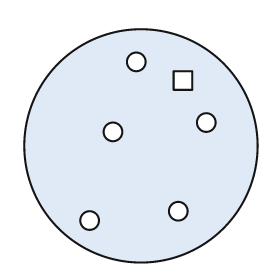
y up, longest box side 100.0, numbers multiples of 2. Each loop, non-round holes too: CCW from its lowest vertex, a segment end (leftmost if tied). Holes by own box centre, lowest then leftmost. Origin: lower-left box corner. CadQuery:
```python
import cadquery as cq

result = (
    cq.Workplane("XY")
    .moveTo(50.0, 50.0)
    .circle(50.0)
    .moveTo(28.0, 18.0)
    .circle(4.0)
    .moveTo(66.0, 22.0)
    .circle(4.0)
    .moveTo(38.0, 56.0)
    .circle(4.0)
    .moveTo(78.0, 60.0)
    .circle(4.0)
    .moveTo(64.0, 74.0)
    .lineTo(72.0, 74.0)
    .lineTo(72.0, 82.0)
    .lineTo(64.0, 82.0)
    .close()
    .moveTo(48.0, 86.0)
    .circle(4.0)
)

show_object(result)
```